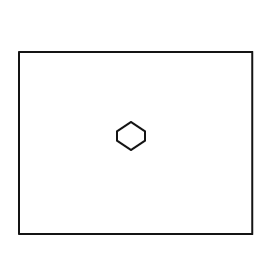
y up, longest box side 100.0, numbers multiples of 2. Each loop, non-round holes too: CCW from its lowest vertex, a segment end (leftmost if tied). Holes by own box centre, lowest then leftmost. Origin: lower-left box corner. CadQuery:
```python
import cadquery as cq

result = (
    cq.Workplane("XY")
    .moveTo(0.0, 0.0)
    .lineTo(100.0, 0.0)
    .lineTo(100.0, 78.0)
    .lineTo(0.0, 78.0)
    .close()
    .moveTo(48.0, 36.0)
    .lineTo(54.0, 40.0)
    .lineTo(54.0, 44.0)
    .lineTo(48.0, 48.0)
    .lineTo(42.0, 44.0)
    .lineTo(42.0, 40.0)
    .close()
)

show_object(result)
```